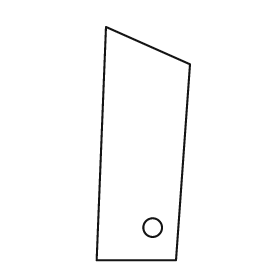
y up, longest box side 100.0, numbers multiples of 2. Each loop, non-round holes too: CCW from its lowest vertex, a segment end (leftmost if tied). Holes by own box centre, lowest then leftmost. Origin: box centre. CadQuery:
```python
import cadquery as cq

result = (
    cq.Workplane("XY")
    .moveTo(-20.0, -50.0)
    .lineTo(14.0, -50.0)
    .lineTo(20.0, 34.0)
    .lineTo(-16.0, 50.0)
    .close()
    .moveTo(4.0, -36.0)
    .circle(4.0)
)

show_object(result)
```